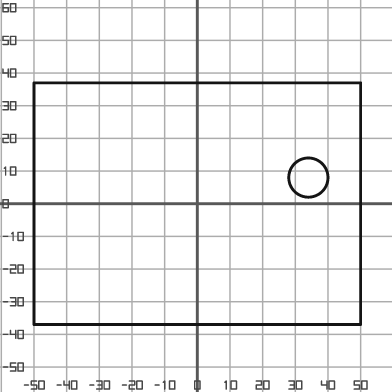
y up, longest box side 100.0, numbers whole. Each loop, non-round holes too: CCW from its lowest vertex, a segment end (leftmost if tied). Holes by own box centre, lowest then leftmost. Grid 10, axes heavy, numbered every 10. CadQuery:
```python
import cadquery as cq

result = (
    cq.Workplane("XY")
    .moveTo(-50.0, -37.0)
    .lineTo(50.0, -37.0)
    .lineTo(50.0, 37.0)
    .lineTo(-50.0, 37.0)
    .close()
    .moveTo(34.0, 8.0)
    .circle(6.0)
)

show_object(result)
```